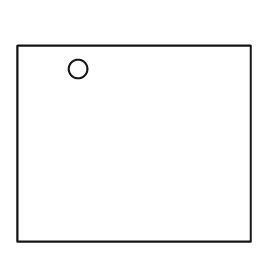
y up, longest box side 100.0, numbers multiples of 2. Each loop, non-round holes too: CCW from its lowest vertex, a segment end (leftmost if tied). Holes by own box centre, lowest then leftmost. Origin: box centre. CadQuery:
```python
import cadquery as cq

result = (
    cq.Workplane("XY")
    .moveTo(-50.0, -42.0)
    .lineTo(50.0, -42.0)
    .lineTo(50.0, 42.0)
    .lineTo(-50.0, 42.0)
    .close()
    .moveTo(-24.0, 32.0)
    .circle(4.0)
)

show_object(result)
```